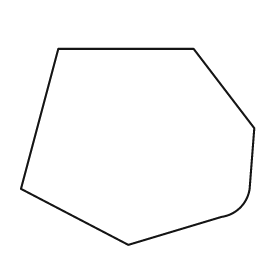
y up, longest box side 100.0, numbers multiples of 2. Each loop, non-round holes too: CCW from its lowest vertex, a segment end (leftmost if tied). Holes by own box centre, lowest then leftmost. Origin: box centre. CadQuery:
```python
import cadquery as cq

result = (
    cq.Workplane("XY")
    .moveTo(-4.0, -42.0)
    .lineTo(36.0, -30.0)
    .threePointArc((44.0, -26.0), (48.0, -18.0))
    .lineTo(50.0, 8.0)
    .lineTo(24.0, 42.0)
    .lineTo(-34.0, 42.0)
    .lineTo(-50.0, -18.0)
    .close()
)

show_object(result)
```